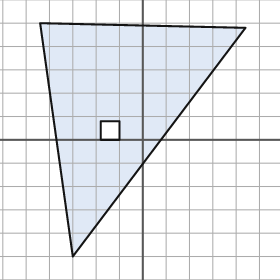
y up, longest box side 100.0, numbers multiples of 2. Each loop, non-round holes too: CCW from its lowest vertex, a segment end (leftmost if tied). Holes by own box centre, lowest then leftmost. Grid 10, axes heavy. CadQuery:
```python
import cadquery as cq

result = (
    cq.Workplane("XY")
    .moveTo(-30.0, -50.0)
    .lineTo(44.0, 48.0)
    .lineTo(-44.0, 50.0)
    .close()
    .moveTo(-18.0, 0.0)
    .lineTo(-10.0, 0.0)
    .lineTo(-10.0, 8.0)
    .lineTo(-18.0, 8.0)
    .close()
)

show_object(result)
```